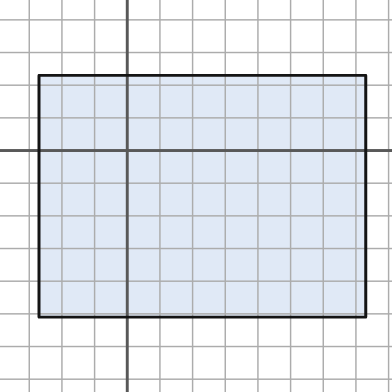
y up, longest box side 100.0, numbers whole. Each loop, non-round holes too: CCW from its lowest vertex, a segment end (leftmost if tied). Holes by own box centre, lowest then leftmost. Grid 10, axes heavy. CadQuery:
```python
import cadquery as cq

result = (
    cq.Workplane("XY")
    .moveTo(-27.0, -51.0)
    .lineTo(73.0, -51.0)
    .lineTo(73.0, 23.0)
    .lineTo(-27.0, 23.0)
    .close()
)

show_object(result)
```